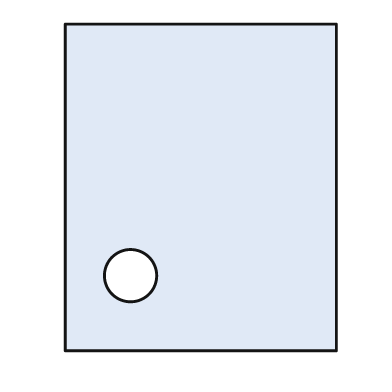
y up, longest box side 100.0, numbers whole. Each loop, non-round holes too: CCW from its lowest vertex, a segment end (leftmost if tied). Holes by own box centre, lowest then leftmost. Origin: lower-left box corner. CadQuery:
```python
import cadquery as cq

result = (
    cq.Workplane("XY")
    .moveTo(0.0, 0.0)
    .lineTo(83.0, 0.0)
    .lineTo(83.0, 100.0)
    .lineTo(0.0, 100.0)
    .close()
    .moveTo(20.0, 23.0)
    .circle(8.0)
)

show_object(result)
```